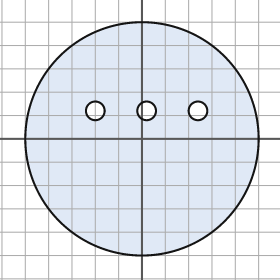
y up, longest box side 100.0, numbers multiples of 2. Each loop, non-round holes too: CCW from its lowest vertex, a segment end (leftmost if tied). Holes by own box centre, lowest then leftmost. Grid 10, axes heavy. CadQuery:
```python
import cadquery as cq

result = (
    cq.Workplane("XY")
    .moveTo(0.0, 0.0)
    .circle(50.0)
    .moveTo(-20.0, 12.0)
    .circle(4.0)
    .moveTo(2.0, 12.0)
    .circle(4.0)
    .moveTo(24.0, 12.0)
    .circle(4.0)
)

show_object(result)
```